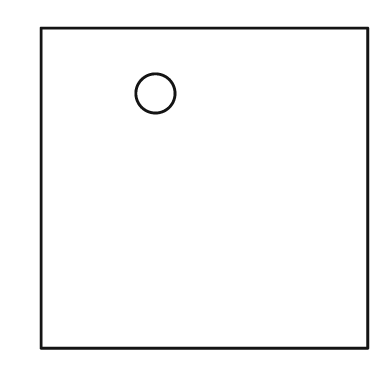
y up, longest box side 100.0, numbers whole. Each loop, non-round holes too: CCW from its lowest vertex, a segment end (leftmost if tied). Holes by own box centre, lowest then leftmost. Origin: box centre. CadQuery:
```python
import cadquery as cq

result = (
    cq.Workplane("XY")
    .moveTo(-50.0, -49.0)
    .lineTo(50.0, -49.0)
    .lineTo(50.0, 49.0)
    .lineTo(-50.0, 49.0)
    .close()
    .moveTo(-15.0, 29.0)
    .circle(6.0)
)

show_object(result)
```